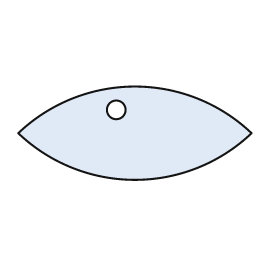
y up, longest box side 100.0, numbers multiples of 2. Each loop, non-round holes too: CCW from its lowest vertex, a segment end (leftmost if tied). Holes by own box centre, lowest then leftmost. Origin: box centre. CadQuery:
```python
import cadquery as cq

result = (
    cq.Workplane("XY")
    .moveTo(-50.0, 0.0)
    .threePointArc((0.0, -20.0), (50.0, 0.0))
    .threePointArc((0.0, 20.0), (-50.0, 0.0))
    .close()
    .moveTo(-8.0, 10.0)
    .circle(4.0)
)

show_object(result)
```